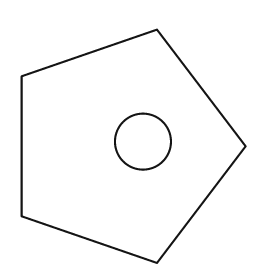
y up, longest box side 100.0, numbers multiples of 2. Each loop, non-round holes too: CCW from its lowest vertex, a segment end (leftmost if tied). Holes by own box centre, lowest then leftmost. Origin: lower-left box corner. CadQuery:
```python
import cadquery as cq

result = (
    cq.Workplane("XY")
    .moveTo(58.0, 0.0)
    .lineTo(96.0, 50.0)
    .lineTo(58.0, 100.0)
    .lineTo(0.0, 80.0)
    .lineTo(0.0, 20.0)
    .close()
    .moveTo(52.0, 52.0)
    .circle(12.0)
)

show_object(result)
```